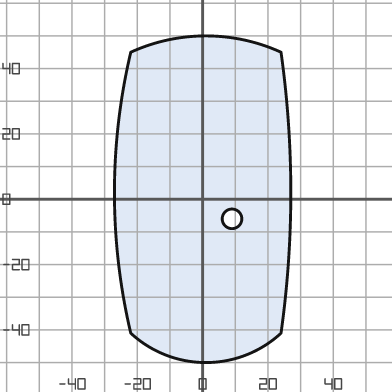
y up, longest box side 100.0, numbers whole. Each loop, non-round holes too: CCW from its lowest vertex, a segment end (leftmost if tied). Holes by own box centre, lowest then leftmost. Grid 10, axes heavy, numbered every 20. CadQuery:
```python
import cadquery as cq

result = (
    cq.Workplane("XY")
    .moveTo(-22.0, -41.0)
    .threePointArc((1.0, -50.0), (24.0, -41.0))
    .threePointArc((27.0, 2.0), (24.0, 45.0))
    .threePointArc((1.0, 50.0), (-22.0, 45.0))
    .threePointArc((-27.0, 2.0), (-22.0, -41.0))
    .close()
    .moveTo(9.0, -6.0)
    .circle(3.0)
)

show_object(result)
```